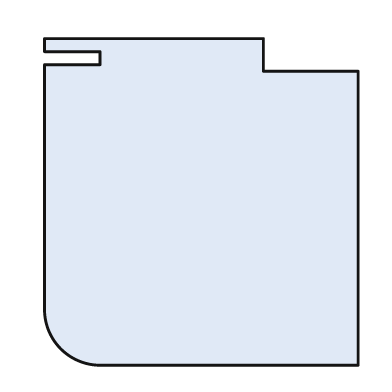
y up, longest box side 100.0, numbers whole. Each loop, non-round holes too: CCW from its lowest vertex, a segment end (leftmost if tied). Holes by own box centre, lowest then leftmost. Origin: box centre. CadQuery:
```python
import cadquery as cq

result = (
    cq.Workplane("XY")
    .moveTo(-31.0, -50.0)
    .lineTo(48.0, -50.0)
    .lineTo(48.0, 40.0)
    .lineTo(19.0, 40.0)
    .lineTo(19.0, 50.0)
    .lineTo(-48.0, 50.0)
    .lineTo(-48.0, 46.0)
    .lineTo(-31.0, 46.0)
    .lineTo(-31.0, 42.0)
    .lineTo(-48.0, 42.0)
    .lineTo(-48.0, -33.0)
    .threePointArc((-43.0, -45.0), (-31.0, -50.0))
    .close()
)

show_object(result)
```